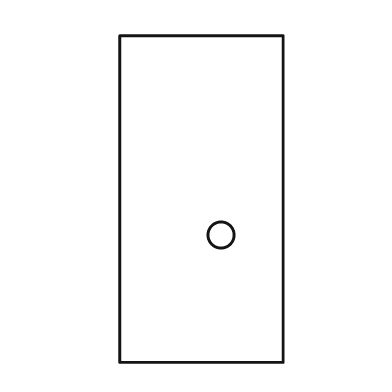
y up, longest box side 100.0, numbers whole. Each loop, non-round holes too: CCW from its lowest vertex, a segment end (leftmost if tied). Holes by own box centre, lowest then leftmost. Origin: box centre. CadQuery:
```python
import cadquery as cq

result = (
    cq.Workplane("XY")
    .moveTo(-25.0, -50.0)
    .lineTo(25.0, -50.0)
    .lineTo(25.0, 50.0)
    .lineTo(-25.0, 50.0)
    .close()
    .moveTo(6.0, -11.0)
    .circle(4.0)
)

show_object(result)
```